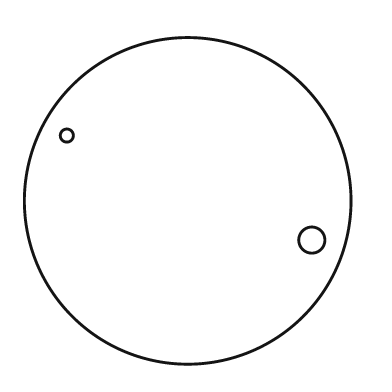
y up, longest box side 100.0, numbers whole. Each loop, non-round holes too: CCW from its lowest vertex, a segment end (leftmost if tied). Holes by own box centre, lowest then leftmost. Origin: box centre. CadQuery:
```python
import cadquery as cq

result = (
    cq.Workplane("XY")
    .moveTo(0.0, 0.0)
    .circle(50.0)
    .moveTo(38.0, -12.0)
    .circle(4.0)
    .moveTo(-37.0, 20.0)
    .circle(2.0)
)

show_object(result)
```